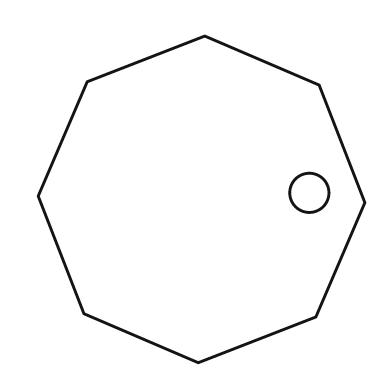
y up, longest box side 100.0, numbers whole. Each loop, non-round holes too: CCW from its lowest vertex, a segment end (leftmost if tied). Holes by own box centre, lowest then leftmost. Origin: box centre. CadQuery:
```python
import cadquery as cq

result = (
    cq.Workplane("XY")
    .moveTo(-1.0, -50.0)
    .lineTo(35.0, -36.0)
    .lineTo(50.0, -1.0)
    .lineTo(36.0, 35.0)
    .lineTo(1.0, 50.0)
    .lineTo(-35.0, 36.0)
    .lineTo(-50.0, 1.0)
    .lineTo(-36.0, -35.0)
    .close()
    .moveTo(33.0, 2.0)
    .circle(6.0)
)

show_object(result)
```